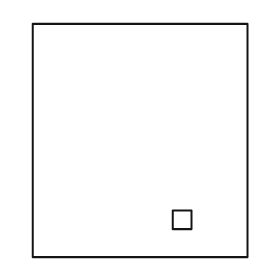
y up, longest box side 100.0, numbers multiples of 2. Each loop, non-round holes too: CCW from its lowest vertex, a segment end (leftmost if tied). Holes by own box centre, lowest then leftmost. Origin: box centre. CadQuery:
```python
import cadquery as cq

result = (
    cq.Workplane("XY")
    .moveTo(-46.0, -50.0)
    .lineTo(46.0, -50.0)
    .lineTo(46.0, 50.0)
    .lineTo(-46.0, 50.0)
    .close()
    .moveTo(14.0, -38.0)
    .lineTo(22.0, -38.0)
    .lineTo(22.0, -30.0)
    .lineTo(14.0, -30.0)
    .close()
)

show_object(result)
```